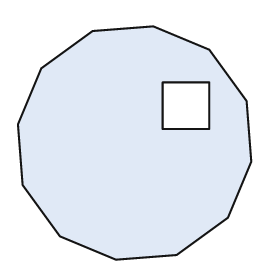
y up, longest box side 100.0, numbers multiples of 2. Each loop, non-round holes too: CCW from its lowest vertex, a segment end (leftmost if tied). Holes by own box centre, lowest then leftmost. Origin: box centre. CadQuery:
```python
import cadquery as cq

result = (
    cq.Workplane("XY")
    .moveTo(-8.0, -50.0)
    .lineTo(18.0, -48.0)
    .lineTo(40.0, -32.0)
    .lineTo(50.0, -8.0)
    .lineTo(48.0, 18.0)
    .lineTo(32.0, 40.0)
    .lineTo(8.0, 50.0)
    .lineTo(-18.0, 48.0)
    .lineTo(-40.0, 32.0)
    .lineTo(-50.0, 8.0)
    .lineTo(-48.0, -18.0)
    .lineTo(-32.0, -40.0)
    .close()
    .moveTo(12.0, 6.0)
    .lineTo(32.0, 6.0)
    .lineTo(32.0, 26.0)
    .lineTo(12.0, 26.0)
    .close()
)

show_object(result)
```